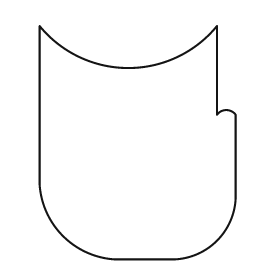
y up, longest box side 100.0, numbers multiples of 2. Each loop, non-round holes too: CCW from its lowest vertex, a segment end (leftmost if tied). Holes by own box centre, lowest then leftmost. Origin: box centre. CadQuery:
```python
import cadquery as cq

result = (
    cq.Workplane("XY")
    .moveTo(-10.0, -50.0)
    .lineTo(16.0, -50.0)
    .threePointArc((34.0, -42.0), (42.0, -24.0))
    .lineTo(42.0, 12.0)
    .threePointArc((38.0, 14.0), (34.0, 12.0))
    .lineTo(34.0, 50.0)
    .threePointArc((-4.0, 32.0), (-42.0, 50.0))
    .lineTo(-42.0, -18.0)
    .threePointArc((-32.0, -40.0), (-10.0, -50.0))
    .close()
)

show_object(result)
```